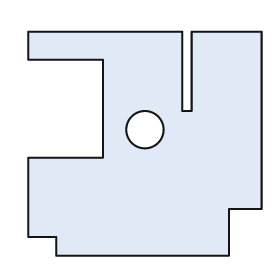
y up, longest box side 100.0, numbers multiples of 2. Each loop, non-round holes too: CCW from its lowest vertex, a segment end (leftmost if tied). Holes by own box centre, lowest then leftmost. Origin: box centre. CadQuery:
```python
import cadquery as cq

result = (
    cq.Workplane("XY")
    .moveTo(-38.0, -48.0)
    .lineTo(36.0, -48.0)
    .lineTo(36.0, -28.0)
    .lineTo(50.0, -28.0)
    .lineTo(50.0, 48.0)
    .lineTo(20.0, 48.0)
    .lineTo(20.0, 14.0)
    .lineTo(16.0, 14.0)
    .lineTo(16.0, 48.0)
    .lineTo(-50.0, 48.0)
    .lineTo(-50.0, 36.0)
    .lineTo(-18.0, 36.0)
    .lineTo(-18.0, -6.0)
    .lineTo(-50.0, -6.0)
    .lineTo(-50.0, -40.0)
    .lineTo(-38.0, -40.0)
    .close()
    .moveTo(0.0, 6.0)
    .circle(8.0)
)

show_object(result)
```